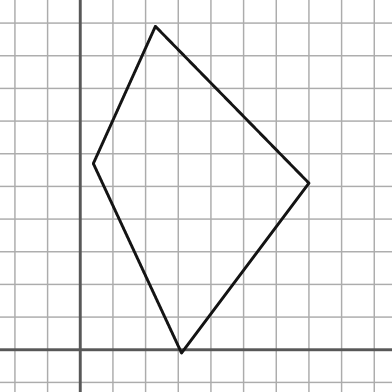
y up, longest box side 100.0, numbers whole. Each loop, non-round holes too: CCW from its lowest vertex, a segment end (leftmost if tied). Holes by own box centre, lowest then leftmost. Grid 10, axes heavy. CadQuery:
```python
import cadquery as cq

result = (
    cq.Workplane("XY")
    .moveTo(31.0, -1.0)
    .lineTo(70.0, 51.0)
    .lineTo(23.0, 99.0)
    .lineTo(4.0, 57.0)
    .close()
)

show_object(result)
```